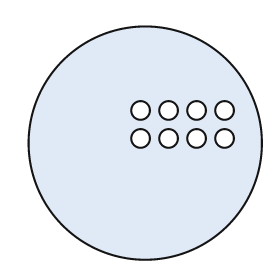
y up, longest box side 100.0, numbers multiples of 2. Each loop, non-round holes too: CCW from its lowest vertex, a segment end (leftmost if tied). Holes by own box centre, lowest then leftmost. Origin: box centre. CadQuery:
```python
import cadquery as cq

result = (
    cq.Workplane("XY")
    .moveTo(0.0, 0.0)
    .circle(50.0)
    .moveTo(-2.0, 2.0)
    .circle(4.0)
    .moveTo(10.0, 2.0)
    .circle(4.0)
    .moveTo(22.0, 2.0)
    .circle(4.0)
    .moveTo(34.0, 2.0)
    .circle(4.0)
    .moveTo(-2.0, 14.0)
    .circle(4.0)
    .moveTo(10.0, 14.0)
    .circle(4.0)
    .moveTo(22.0, 14.0)
    .circle(4.0)
    .moveTo(34.0, 14.0)
    .circle(4.0)
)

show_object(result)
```